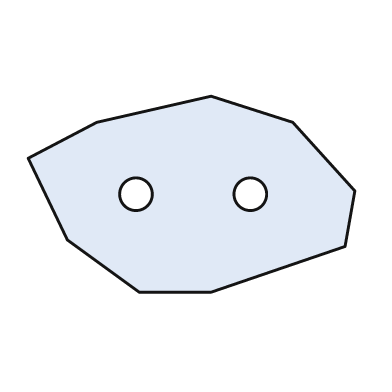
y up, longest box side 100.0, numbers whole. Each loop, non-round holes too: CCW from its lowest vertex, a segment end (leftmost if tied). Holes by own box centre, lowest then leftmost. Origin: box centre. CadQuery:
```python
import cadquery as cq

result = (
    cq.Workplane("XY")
    .moveTo(-16.0, -30.0)
    .lineTo(6.0, -30.0)
    .lineTo(47.0, -16.0)
    .lineTo(50.0, 1.0)
    .lineTo(31.0, 22.0)
    .lineTo(6.0, 30.0)
    .lineTo(-29.0, 22.0)
    .lineTo(-50.0, 11.0)
    .lineTo(-38.0, -14.0)
    .close()
    .moveTo(-17.0, 0.0)
    .circle(5.0)
    .moveTo(18.0, 0.0)
    .circle(5.0)
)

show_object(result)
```